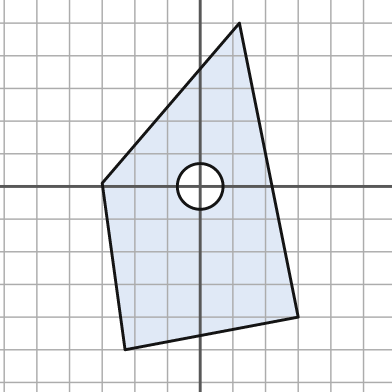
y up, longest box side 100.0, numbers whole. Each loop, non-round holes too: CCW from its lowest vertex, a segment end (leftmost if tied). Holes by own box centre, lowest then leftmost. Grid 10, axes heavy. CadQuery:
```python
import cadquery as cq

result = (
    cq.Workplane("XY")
    .moveTo(-23.0, -50.0)
    .lineTo(30.0, -40.0)
    .lineTo(12.0, 50.0)
    .lineTo(-30.0, 1.0)
    .close()
    .moveTo(0.0, 0.0)
    .circle(7.0)
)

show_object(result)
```